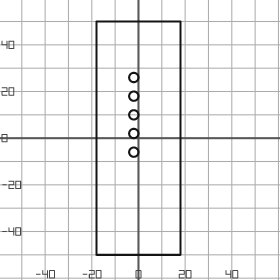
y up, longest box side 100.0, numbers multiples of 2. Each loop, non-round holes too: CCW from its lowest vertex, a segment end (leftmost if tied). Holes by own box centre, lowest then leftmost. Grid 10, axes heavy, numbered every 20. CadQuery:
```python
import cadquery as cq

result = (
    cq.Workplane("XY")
    .moveTo(-18.0, -50.0)
    .lineTo(18.0, -50.0)
    .lineTo(18.0, 50.0)
    .lineTo(-18.0, 50.0)
    .close()
    .moveTo(-2.0, -6.0)
    .circle(2.0)
    .moveTo(-2.0, 2.0)
    .circle(2.0)
    .moveTo(-2.0, 10.0)
    .circle(2.0)
    .moveTo(-2.0, 18.0)
    .circle(2.0)
    .moveTo(-2.0, 26.0)
    .circle(2.0)
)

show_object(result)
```